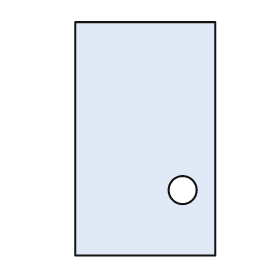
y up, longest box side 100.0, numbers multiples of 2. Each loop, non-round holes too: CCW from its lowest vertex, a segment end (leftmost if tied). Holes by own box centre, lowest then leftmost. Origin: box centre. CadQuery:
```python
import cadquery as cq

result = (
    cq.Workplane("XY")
    .moveTo(-30.0, -50.0)
    .lineTo(30.0, -50.0)
    .lineTo(30.0, 50.0)
    .lineTo(-30.0, 50.0)
    .close()
    .moveTo(16.0, -22.0)
    .circle(6.0)
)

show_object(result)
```